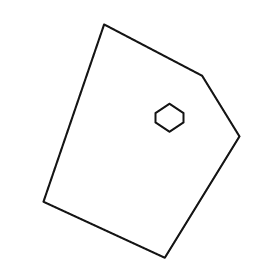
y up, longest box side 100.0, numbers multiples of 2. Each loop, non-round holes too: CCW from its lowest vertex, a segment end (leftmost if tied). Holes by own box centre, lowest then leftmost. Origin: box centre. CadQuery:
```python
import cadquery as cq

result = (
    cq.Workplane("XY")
    .moveTo(10.0, -50.0)
    .lineTo(42.0, 2.0)
    .lineTo(26.0, 28.0)
    .lineTo(-16.0, 50.0)
    .lineTo(-42.0, -26.0)
    .close()
    .moveTo(12.0, 4.0)
    .lineTo(18.0, 8.0)
    .lineTo(18.0, 12.0)
    .lineTo(12.0, 16.0)
    .lineTo(6.0, 12.0)
    .lineTo(6.0, 8.0)
    .close()
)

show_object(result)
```